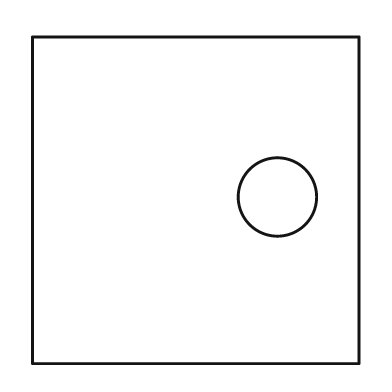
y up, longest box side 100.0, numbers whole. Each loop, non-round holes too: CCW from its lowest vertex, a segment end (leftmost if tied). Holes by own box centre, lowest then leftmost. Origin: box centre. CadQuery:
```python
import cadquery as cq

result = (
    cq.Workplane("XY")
    .moveTo(-50.0, -50.0)
    .lineTo(50.0, -50.0)
    .lineTo(50.0, 50.0)
    .lineTo(-50.0, 50.0)
    .close()
    .moveTo(25.0, 1.0)
    .circle(12.0)
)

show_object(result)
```